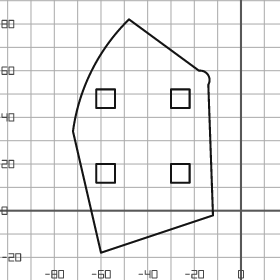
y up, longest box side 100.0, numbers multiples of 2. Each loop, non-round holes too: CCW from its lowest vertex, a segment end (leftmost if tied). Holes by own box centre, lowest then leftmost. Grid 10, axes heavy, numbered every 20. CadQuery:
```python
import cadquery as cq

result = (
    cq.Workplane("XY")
    .moveTo(-60.0, -18.0)
    .lineTo(-12.0, -2.0)
    .lineTo(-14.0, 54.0)
    .threePointArc((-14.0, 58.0), (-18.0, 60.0))
    .lineTo(-48.0, 82.0)
    .threePointArc((-64.0, 60.0), (-72.0, 34.0))
    .close()
    .moveTo(-62.0, 12.0)
    .lineTo(-54.0, 12.0)
    .lineTo(-54.0, 20.0)
    .lineTo(-62.0, 20.0)
    .close()
    .moveTo(-30.0, 12.0)
    .lineTo(-22.0, 12.0)
    .lineTo(-22.0, 20.0)
    .lineTo(-30.0, 20.0)
    .close()
    .moveTo(-62.0, 44.0)
    .lineTo(-54.0, 44.0)
    .lineTo(-54.0, 52.0)
    .lineTo(-62.0, 52.0)
    .close()
    .moveTo(-30.0, 44.0)
    .lineTo(-22.0, 44.0)
    .lineTo(-22.0, 52.0)
    .lineTo(-30.0, 52.0)
    .close()
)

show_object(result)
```